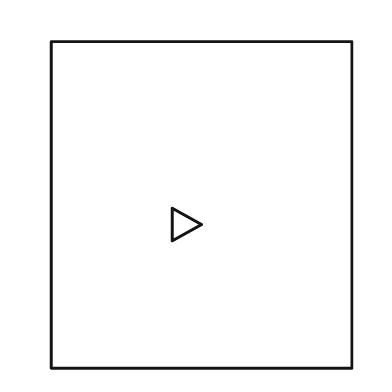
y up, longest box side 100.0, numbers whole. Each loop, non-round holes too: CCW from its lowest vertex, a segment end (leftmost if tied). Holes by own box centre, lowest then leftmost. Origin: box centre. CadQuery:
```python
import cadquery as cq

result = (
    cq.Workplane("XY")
    .moveTo(-46.0, -50.0)
    .lineTo(46.0, -50.0)
    .lineTo(46.0, 50.0)
    .lineTo(-46.0, 50.0)
    .close()
    .moveTo(-9.0, -11.0)
    .lineTo(0.0, -6.0)
    .lineTo(-9.0, -1.0)
    .close()
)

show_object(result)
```